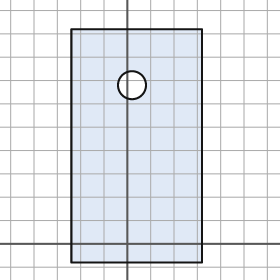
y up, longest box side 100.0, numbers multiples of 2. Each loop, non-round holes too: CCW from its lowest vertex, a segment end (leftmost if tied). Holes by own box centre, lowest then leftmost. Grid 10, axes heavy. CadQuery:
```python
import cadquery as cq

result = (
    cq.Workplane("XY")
    .moveTo(-24.0, -8.0)
    .lineTo(32.0, -8.0)
    .lineTo(32.0, 92.0)
    .lineTo(-24.0, 92.0)
    .close()
    .moveTo(2.0, 68.0)
    .circle(6.0)
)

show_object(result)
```